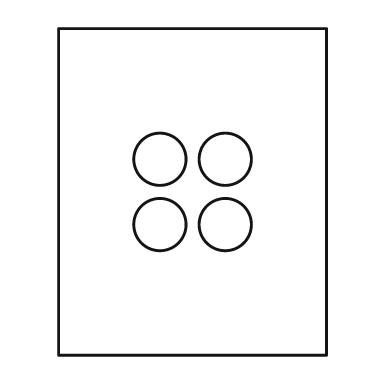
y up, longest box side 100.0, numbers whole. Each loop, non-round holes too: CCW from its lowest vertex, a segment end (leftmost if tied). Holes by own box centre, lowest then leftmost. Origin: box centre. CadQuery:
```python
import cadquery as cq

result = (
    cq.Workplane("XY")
    .moveTo(-41.0, -50.0)
    .lineTo(41.0, -50.0)
    .lineTo(41.0, 50.0)
    .lineTo(-41.0, 50.0)
    .close()
    .moveTo(-10.0, -10.0)
    .circle(8.0)
    .moveTo(10.0, -10.0)
    .circle(8.0)
    .moveTo(-10.0, 10.0)
    .circle(8.0)
    .moveTo(10.0, 10.0)
    .circle(8.0)
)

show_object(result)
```